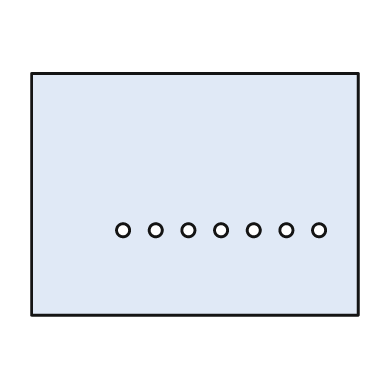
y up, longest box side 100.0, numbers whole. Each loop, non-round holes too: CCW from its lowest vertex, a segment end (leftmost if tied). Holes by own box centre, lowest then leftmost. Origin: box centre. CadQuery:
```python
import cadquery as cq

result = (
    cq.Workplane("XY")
    .moveTo(-50.0, -37.0)
    .lineTo(50.0, -37.0)
    .lineTo(50.0, 37.0)
    .lineTo(-50.0, 37.0)
    .close()
    .moveTo(-22.0, -11.0)
    .circle(2.0)
    .moveTo(-12.0, -11.0)
    .circle(2.0)
    .moveTo(-2.0, -11.0)
    .circle(2.0)
    .moveTo(8.0, -11.0)
    .circle(2.0)
    .moveTo(18.0, -11.0)
    .circle(2.0)
    .moveTo(28.0, -11.0)
    .circle(2.0)
    .moveTo(38.0, -11.0)
    .circle(2.0)
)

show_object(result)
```